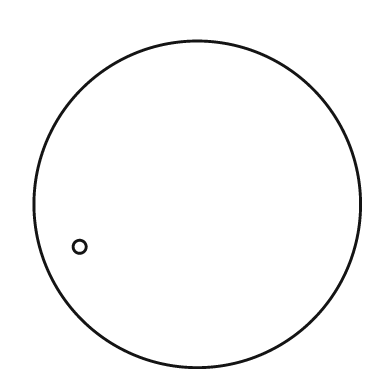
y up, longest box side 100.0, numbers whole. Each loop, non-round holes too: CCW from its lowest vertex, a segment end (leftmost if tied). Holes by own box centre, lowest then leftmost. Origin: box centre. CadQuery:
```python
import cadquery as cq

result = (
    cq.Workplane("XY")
    .moveTo(0.0, 0.0)
    .circle(50.0)
    .moveTo(-36.0, -13.0)
    .circle(2.0)
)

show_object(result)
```